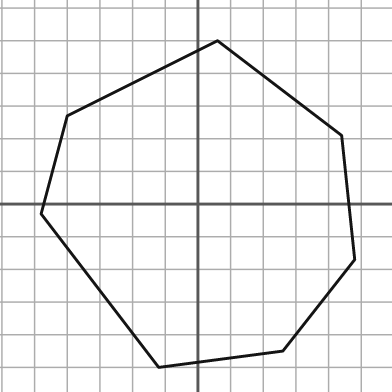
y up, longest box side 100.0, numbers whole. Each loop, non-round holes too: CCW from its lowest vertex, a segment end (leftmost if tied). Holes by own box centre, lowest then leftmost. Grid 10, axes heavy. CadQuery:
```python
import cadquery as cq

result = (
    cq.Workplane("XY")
    .moveTo(-12.0, -50.0)
    .lineTo(26.0, -45.0)
    .lineTo(48.0, -17.0)
    .lineTo(44.0, 21.0)
    .lineTo(6.0, 50.0)
    .lineTo(-40.0, 27.0)
    .lineTo(-48.0, -3.0)
    .close()
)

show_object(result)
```